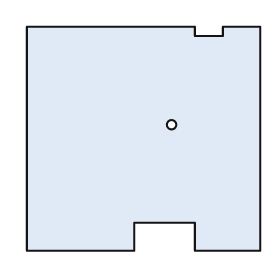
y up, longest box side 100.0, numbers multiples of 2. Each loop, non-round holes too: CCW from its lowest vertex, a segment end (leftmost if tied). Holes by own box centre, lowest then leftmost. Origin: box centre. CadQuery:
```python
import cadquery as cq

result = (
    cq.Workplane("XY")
    .moveTo(-50.0, -48.0)
    .lineTo(-4.0, -48.0)
    .lineTo(-4.0, -36.0)
    .lineTo(22.0, -36.0)
    .lineTo(22.0, -48.0)
    .lineTo(50.0, -48.0)
    .lineTo(50.0, 48.0)
    .lineTo(34.0, 48.0)
    .lineTo(34.0, 44.0)
    .lineTo(22.0, 44.0)
    .lineTo(22.0, 48.0)
    .lineTo(-50.0, 48.0)
    .close()
    .moveTo(12.0, 6.0)
    .circle(2.0)
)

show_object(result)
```